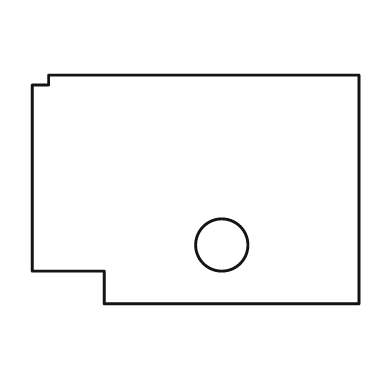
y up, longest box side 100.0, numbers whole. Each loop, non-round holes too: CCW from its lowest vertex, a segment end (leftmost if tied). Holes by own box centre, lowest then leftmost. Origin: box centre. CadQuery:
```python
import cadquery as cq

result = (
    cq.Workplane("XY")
    .moveTo(-28.0, -35.0)
    .lineTo(50.0, -35.0)
    .lineTo(50.0, 35.0)
    .lineTo(-45.0, 35.0)
    .lineTo(-45.0, 32.0)
    .lineTo(-50.0, 32.0)
    .lineTo(-50.0, -25.0)
    .lineTo(-28.0, -25.0)
    .close()
    .moveTo(8.0, -17.0)
    .circle(8.0)
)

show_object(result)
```